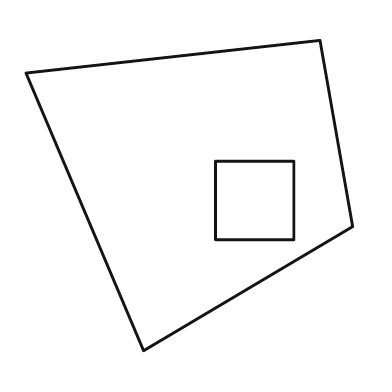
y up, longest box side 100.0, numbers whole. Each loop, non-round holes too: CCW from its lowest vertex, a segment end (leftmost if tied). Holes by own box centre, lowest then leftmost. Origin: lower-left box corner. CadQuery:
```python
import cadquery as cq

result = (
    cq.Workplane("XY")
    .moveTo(36.0, 0.0)
    .lineTo(100.0, 38.0)
    .lineTo(90.0, 95.0)
    .lineTo(0.0, 85.0)
    .close()
    .moveTo(58.0, 34.0)
    .lineTo(82.0, 34.0)
    .lineTo(82.0, 58.0)
    .lineTo(58.0, 58.0)
    .close()
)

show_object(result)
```